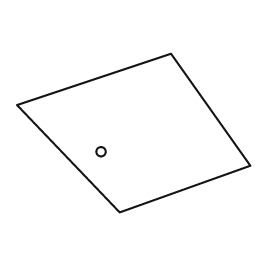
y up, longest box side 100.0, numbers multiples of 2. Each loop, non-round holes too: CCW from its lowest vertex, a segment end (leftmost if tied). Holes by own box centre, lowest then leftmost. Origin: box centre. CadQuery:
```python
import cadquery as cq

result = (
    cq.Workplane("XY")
    .moveTo(-6.0, -34.0)
    .lineTo(50.0, -14.0)
    .lineTo(16.0, 34.0)
    .lineTo(-50.0, 12.0)
    .close()
    .moveTo(-14.0, -8.0)
    .circle(2.0)
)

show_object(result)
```